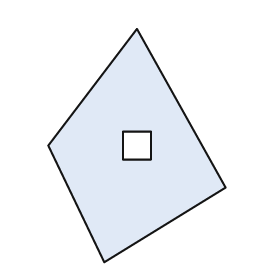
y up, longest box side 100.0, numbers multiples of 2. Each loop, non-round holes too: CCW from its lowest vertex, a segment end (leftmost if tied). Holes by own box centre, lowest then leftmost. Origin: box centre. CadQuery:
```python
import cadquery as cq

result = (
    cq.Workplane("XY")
    .moveTo(-14.0, -50.0)
    .lineTo(38.0, -18.0)
    .lineTo(0.0, 50.0)
    .lineTo(-38.0, 0.0)
    .close()
    .moveTo(-6.0, -6.0)
    .lineTo(6.0, -6.0)
    .lineTo(6.0, 6.0)
    .lineTo(-6.0, 6.0)
    .close()
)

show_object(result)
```